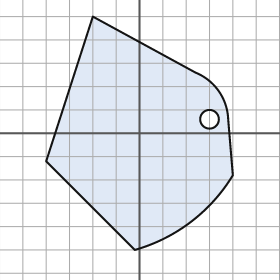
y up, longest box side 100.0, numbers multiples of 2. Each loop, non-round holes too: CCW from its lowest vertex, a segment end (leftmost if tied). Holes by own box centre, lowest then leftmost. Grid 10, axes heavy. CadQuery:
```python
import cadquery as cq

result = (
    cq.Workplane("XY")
    .moveTo(-2.0, -50.0)
    .threePointArc((22.0, -38.0), (40.0, -18.0))
    .lineTo(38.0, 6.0)
    .threePointArc((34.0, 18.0), (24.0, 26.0))
    .lineTo(-20.0, 50.0)
    .lineTo(-40.0, -12.0)
    .close()
    .moveTo(30.0, 6.0)
    .circle(4.0)
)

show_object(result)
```